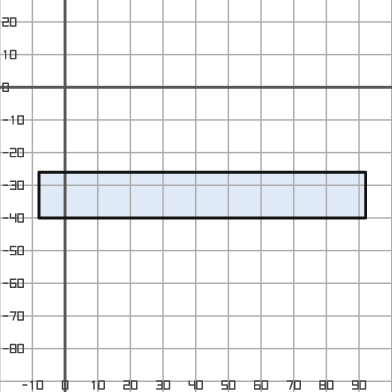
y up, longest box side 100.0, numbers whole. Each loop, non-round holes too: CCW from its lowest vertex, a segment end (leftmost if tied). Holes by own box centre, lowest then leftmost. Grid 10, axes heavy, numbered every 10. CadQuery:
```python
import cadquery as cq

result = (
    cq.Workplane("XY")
    .moveTo(-8.0, -40.0)
    .lineTo(92.0, -40.0)
    .lineTo(92.0, -26.0)
    .lineTo(-8.0, -26.0)
    .close()
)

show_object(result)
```